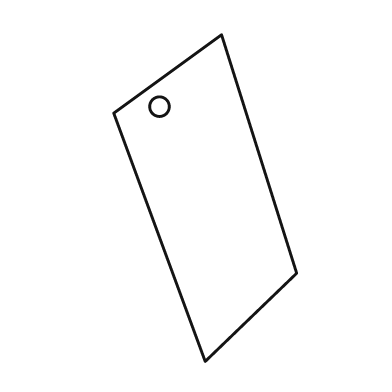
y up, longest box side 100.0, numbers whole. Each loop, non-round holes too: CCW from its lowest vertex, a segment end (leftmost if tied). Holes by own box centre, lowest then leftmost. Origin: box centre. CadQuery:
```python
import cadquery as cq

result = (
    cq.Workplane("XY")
    .moveTo(0.0, -50.0)
    .lineTo(28.0, -23.0)
    .lineTo(5.0, 50.0)
    .lineTo(-28.0, 26.0)
    .close()
    .moveTo(-14.0, 28.0)
    .circle(3.0)
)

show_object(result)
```